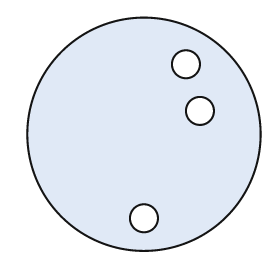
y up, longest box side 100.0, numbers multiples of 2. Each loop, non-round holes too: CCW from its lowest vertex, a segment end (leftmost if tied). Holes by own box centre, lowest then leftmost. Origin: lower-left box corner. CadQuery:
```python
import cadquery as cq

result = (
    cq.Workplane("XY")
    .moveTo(50.0, 50.0)
    .circle(50.0)
    .moveTo(50.0, 14.0)
    .circle(6.0)
    .moveTo(74.0, 60.0)
    .circle(6.0)
    .moveTo(68.0, 80.0)
    .circle(6.0)
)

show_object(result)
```